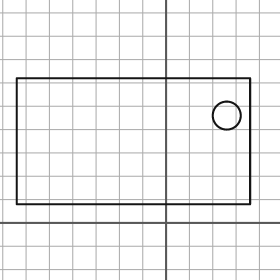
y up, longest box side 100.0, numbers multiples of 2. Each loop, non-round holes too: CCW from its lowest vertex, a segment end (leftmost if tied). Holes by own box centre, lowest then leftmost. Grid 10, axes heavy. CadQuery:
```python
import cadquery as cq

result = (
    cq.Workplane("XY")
    .moveTo(-64.0, 8.0)
    .lineTo(36.0, 8.0)
    .lineTo(36.0, 62.0)
    .lineTo(-64.0, 62.0)
    .close()
    .moveTo(26.0, 46.0)
    .circle(6.0)
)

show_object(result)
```